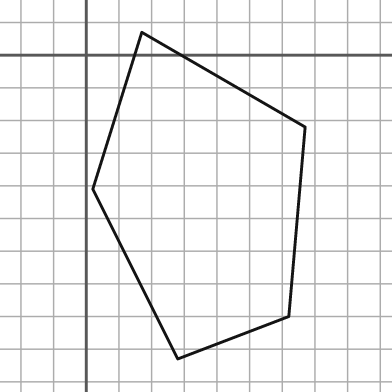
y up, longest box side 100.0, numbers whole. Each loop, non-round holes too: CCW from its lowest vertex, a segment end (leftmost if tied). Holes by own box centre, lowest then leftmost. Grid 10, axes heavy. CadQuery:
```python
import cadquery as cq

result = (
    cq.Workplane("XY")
    .moveTo(28.0, -93.0)
    .lineTo(62.0, -80.0)
    .lineTo(67.0, -22.0)
    .lineTo(17.0, 7.0)
    .lineTo(2.0, -41.0)
    .close()
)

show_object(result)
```